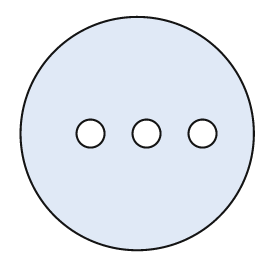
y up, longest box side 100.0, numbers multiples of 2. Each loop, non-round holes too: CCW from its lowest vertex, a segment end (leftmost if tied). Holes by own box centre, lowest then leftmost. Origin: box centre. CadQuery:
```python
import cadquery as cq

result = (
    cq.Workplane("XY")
    .moveTo(0.0, 0.0)
    .circle(50.0)
    .moveTo(-20.0, 0.0)
    .circle(6.0)
    .moveTo(4.0, 0.0)
    .circle(6.0)
    .moveTo(28.0, 0.0)
    .circle(6.0)
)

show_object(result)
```